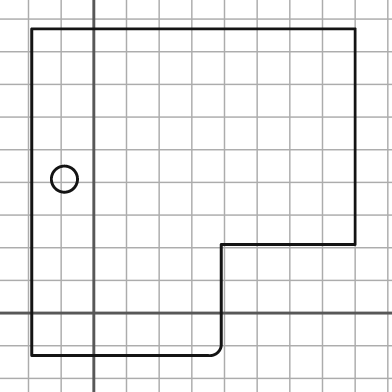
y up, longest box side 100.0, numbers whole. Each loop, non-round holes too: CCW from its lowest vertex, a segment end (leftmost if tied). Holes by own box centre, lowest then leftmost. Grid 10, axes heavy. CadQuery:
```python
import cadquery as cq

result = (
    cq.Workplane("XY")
    .moveTo(-19.0, -13.0)
    .lineTo(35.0, -13.0)
    .threePointArc((38.0, -12.0), (39.0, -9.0))
    .lineTo(39.0, 21.0)
    .lineTo(80.0, 21.0)
    .lineTo(80.0, 87.0)
    .lineTo(-19.0, 87.0)
    .close()
    .moveTo(-9.0, 41.0)
    .circle(4.0)
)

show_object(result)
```